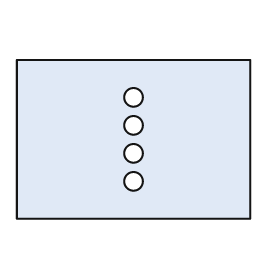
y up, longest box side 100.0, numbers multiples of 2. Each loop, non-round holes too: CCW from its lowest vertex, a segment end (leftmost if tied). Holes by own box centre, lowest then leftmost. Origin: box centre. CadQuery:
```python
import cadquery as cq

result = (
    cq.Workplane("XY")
    .moveTo(-50.0, -34.0)
    .lineTo(50.0, -34.0)
    .lineTo(50.0, 34.0)
    .lineTo(-50.0, 34.0)
    .close()
    .moveTo(0.0, -18.0)
    .circle(4.0)
    .moveTo(0.0, -6.0)
    .circle(4.0)
    .moveTo(0.0, 6.0)
    .circle(4.0)
    .moveTo(0.0, 18.0)
    .circle(4.0)
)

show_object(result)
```